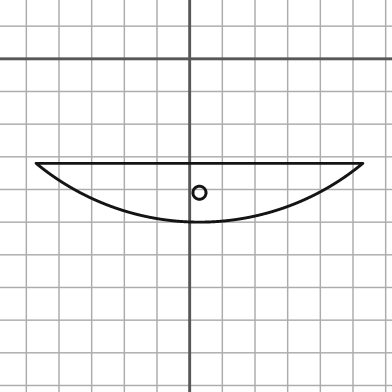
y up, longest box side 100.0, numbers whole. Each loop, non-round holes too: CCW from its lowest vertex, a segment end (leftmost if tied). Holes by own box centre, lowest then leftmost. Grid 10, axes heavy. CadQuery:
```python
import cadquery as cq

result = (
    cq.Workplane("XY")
    .moveTo(-47.0, -32.0)
    .threePointArc((3.0, -50.0), (53.0, -32.0))
    .close()
    .moveTo(3.0, -41.0)
    .circle(2.0)
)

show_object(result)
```